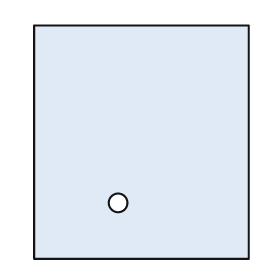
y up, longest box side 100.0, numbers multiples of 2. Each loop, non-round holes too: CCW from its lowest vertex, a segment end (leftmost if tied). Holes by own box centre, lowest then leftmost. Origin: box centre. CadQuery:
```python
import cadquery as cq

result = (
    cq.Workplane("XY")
    .moveTo(-46.0, -50.0)
    .lineTo(46.0, -50.0)
    .lineTo(46.0, 50.0)
    .lineTo(-46.0, 50.0)
    .close()
    .moveTo(-10.0, -26.0)
    .circle(4.0)
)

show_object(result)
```